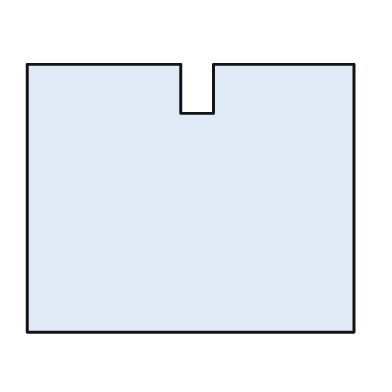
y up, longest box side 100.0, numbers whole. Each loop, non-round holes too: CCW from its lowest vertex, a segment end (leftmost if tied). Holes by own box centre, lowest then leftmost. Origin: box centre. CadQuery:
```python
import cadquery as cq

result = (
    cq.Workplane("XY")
    .moveTo(-50.0, -41.0)
    .lineTo(50.0, -41.0)
    .lineTo(50.0, 41.0)
    .lineTo(7.0, 41.0)
    .lineTo(7.0, 26.0)
    .lineTo(-3.0, 26.0)
    .lineTo(-3.0, 41.0)
    .lineTo(-50.0, 41.0)
    .close()
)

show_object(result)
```